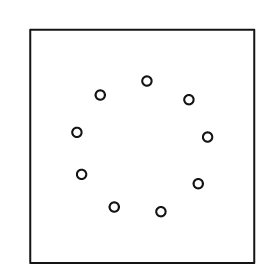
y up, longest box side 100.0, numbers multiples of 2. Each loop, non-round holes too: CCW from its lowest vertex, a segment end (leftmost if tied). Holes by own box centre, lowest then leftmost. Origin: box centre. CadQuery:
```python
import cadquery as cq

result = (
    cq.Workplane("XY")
    .moveTo(-48.0, -50.0)
    .lineTo(48.0, -50.0)
    .lineTo(48.0, 50.0)
    .lineTo(-48.0, 50.0)
    .close()
    .moveTo(8.0, -28.0)
    .circle(2.0)
    .moveTo(-12.0, -26.0)
    .circle(2.0)
    .moveTo(24.0, -16.0)
    .circle(2.0)
    .moveTo(-26.0, -12.0)
    .circle(2.0)
    .moveTo(28.0, 4.0)
    .circle(2.0)
    .moveTo(-28.0, 6.0)
    .circle(2.0)
    .moveTo(20.0, 20.0)
    .circle(2.0)
    .moveTo(-18.0, 22.0)
    .circle(2.0)
    .moveTo(2.0, 28.0)
    .circle(2.0)
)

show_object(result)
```